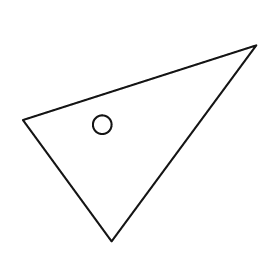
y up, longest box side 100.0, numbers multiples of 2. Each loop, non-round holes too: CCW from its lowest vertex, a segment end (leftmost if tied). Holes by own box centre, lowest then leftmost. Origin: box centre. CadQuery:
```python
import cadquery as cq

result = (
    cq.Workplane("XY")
    .moveTo(-12.0, -42.0)
    .lineTo(50.0, 42.0)
    .lineTo(-50.0, 10.0)
    .close()
    .moveTo(-16.0, 8.0)
    .circle(4.0)
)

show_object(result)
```